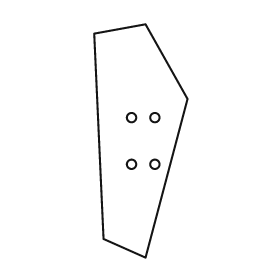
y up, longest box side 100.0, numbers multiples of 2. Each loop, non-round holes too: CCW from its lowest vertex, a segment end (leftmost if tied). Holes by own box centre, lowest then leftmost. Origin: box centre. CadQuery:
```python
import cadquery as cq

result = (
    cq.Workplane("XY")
    .moveTo(2.0, -50.0)
    .lineTo(20.0, 18.0)
    .lineTo(2.0, 50.0)
    .lineTo(-20.0, 46.0)
    .lineTo(-16.0, -42.0)
    .close()
    .moveTo(-4.0, -10.0)
    .circle(2.0)
    .moveTo(6.0, -10.0)
    .circle(2.0)
    .moveTo(-4.0, 10.0)
    .circle(2.0)
    .moveTo(6.0, 10.0)
    .circle(2.0)
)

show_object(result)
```